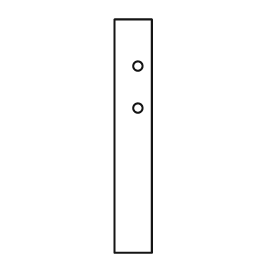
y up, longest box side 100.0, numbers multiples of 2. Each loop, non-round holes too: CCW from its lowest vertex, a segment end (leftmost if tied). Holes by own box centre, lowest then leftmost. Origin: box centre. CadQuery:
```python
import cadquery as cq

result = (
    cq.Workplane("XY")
    .moveTo(-8.0, -50.0)
    .lineTo(8.0, -50.0)
    .lineTo(8.0, 50.0)
    .lineTo(-8.0, 50.0)
    .close()
    .moveTo(2.0, 12.0)
    .circle(2.0)
    .moveTo(2.0, 30.0)
    .circle(2.0)
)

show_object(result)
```